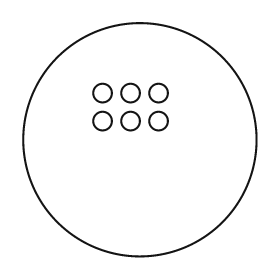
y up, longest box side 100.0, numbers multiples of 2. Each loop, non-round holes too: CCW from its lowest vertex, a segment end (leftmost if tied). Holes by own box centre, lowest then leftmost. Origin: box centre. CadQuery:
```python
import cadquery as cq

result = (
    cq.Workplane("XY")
    .moveTo(0.0, 0.0)
    .circle(50.0)
    .moveTo(-16.0, 8.0)
    .circle(4.0)
    .moveTo(-4.0, 8.0)
    .circle(4.0)
    .moveTo(8.0, 8.0)
    .circle(4.0)
    .moveTo(-16.0, 20.0)
    .circle(4.0)
    .moveTo(-4.0, 20.0)
    .circle(4.0)
    .moveTo(8.0, 20.0)
    .circle(4.0)
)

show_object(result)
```